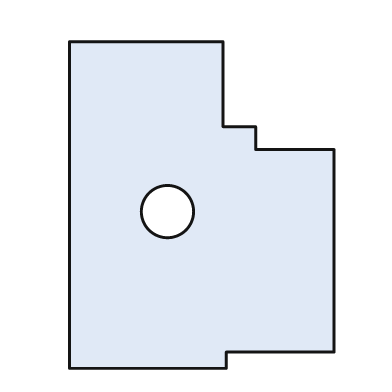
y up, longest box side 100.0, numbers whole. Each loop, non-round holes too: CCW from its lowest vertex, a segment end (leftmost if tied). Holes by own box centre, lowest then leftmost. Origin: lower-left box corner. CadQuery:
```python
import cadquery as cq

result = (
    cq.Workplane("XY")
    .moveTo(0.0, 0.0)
    .lineTo(48.0, 0.0)
    .lineTo(48.0, 5.0)
    .lineTo(81.0, 5.0)
    .lineTo(81.0, 67.0)
    .lineTo(57.0, 67.0)
    .lineTo(57.0, 74.0)
    .lineTo(47.0, 74.0)
    .lineTo(47.0, 100.0)
    .lineTo(0.0, 100.0)
    .close()
    .moveTo(30.0, 48.0)
    .circle(8.0)
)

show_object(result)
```